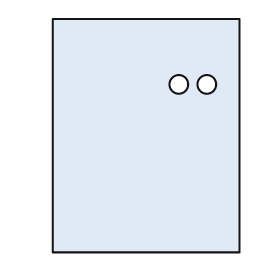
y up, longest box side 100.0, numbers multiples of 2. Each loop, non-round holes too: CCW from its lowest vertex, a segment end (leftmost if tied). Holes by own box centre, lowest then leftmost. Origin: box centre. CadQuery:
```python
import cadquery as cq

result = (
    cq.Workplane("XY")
    .moveTo(-40.0, -50.0)
    .lineTo(40.0, -50.0)
    .lineTo(40.0, 50.0)
    .lineTo(-40.0, 50.0)
    .close()
    .moveTo(14.0, 22.0)
    .circle(4.0)
    .moveTo(26.0, 22.0)
    .circle(4.0)
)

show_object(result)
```